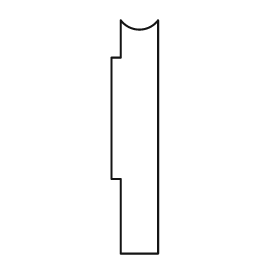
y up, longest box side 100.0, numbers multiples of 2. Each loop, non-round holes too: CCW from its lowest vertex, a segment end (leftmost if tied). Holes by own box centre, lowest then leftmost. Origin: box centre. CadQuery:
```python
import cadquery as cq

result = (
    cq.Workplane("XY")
    .moveTo(-6.0, -50.0)
    .lineTo(10.0, -50.0)
    .lineTo(10.0, 50.0)
    .threePointArc((2.0, 46.0), (-6.0, 50.0))
    .lineTo(-6.0, 34.0)
    .lineTo(-10.0, 34.0)
    .lineTo(-10.0, -18.0)
    .lineTo(-6.0, -18.0)
    .close()
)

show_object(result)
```